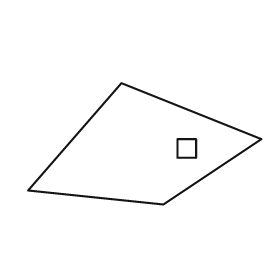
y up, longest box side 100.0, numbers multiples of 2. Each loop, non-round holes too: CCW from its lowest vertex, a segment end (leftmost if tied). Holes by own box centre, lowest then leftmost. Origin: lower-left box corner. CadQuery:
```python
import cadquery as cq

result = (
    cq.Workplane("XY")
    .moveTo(58.0, 0.0)
    .lineTo(100.0, 28.0)
    .lineTo(40.0, 52.0)
    .lineTo(0.0, 6.0)
    .close()
    .moveTo(64.0, 20.0)
    .lineTo(72.0, 20.0)
    .lineTo(72.0, 28.0)
    .lineTo(64.0, 28.0)
    .close()
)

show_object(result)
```